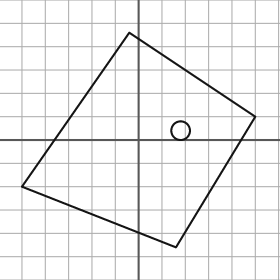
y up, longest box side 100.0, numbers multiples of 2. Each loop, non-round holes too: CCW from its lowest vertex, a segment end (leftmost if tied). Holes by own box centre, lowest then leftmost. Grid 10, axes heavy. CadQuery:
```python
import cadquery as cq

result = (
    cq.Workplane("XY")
    .moveTo(16.0, -46.0)
    .lineTo(50.0, 10.0)
    .lineTo(-4.0, 46.0)
    .lineTo(-50.0, -20.0)
    .close()
    .moveTo(18.0, 4.0)
    .circle(4.0)
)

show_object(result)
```